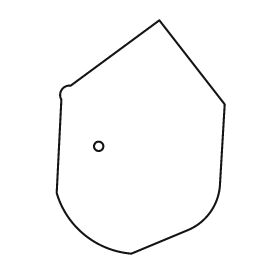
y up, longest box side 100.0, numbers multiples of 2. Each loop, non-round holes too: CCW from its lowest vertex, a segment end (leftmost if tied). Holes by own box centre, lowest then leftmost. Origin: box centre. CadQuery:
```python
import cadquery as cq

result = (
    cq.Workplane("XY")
    .moveTo(-4.0, -50.0)
    .lineTo(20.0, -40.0)
    .threePointArc((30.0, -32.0), (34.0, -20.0))
    .lineTo(36.0, 14.0)
    .lineTo(8.0, 50.0)
    .lineTo(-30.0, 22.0)
    .threePointArc((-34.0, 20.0), (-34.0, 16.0))
    .lineTo(-36.0, -24.0)
    .threePointArc((-24.0, -42.0), (-4.0, -50.0))
    .close()
    .moveTo(-18.0, -4.0)
    .circle(2.0)
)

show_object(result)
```